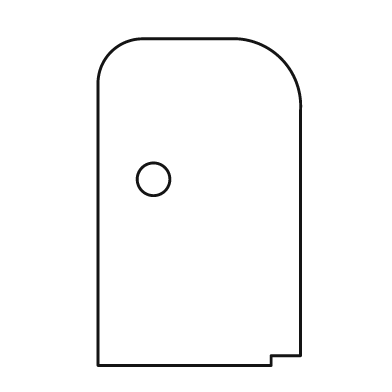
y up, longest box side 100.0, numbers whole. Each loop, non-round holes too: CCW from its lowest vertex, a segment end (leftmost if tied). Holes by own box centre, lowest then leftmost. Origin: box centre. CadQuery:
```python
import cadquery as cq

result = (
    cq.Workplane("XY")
    .moveTo(-31.0, -50.0)
    .lineTo(22.0, -50.0)
    .lineTo(22.0, -47.0)
    .lineTo(31.0, -47.0)
    .lineTo(31.0, 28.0)
    .threePointArc((25.0, 44.0), (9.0, 50.0))
    .lineTo(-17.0, 50.0)
    .threePointArc((-27.0, 46.0), (-31.0, 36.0))
    .close()
    .moveTo(-14.0, 7.0)
    .circle(5.0)
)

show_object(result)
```